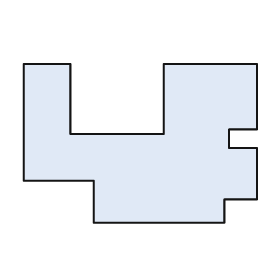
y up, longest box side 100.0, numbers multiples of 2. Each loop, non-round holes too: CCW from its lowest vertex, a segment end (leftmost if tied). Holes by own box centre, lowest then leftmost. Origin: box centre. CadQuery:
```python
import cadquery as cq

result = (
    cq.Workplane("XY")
    .moveTo(-20.0, -34.0)
    .lineTo(36.0, -34.0)
    .lineTo(36.0, -24.0)
    .lineTo(50.0, -24.0)
    .lineTo(50.0, -2.0)
    .lineTo(38.0, -2.0)
    .lineTo(38.0, 6.0)
    .lineTo(50.0, 6.0)
    .lineTo(50.0, 34.0)
    .lineTo(10.0, 34.0)
    .lineTo(10.0, 4.0)
    .lineTo(-30.0, 4.0)
    .lineTo(-30.0, 34.0)
    .lineTo(-50.0, 34.0)
    .lineTo(-50.0, -16.0)
    .lineTo(-20.0, -16.0)
    .close()
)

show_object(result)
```